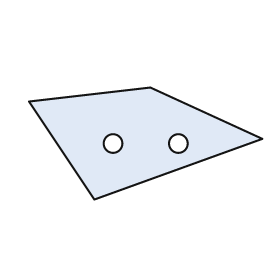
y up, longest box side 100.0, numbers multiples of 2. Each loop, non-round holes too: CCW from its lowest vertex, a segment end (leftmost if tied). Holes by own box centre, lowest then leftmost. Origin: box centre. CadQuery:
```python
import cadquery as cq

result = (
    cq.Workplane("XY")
    .moveTo(-22.0, -24.0)
    .lineTo(50.0, 2.0)
    .lineTo(2.0, 24.0)
    .lineTo(-50.0, 18.0)
    .close()
    .moveTo(-14.0, 0.0)
    .circle(4.0)
    .moveTo(14.0, 0.0)
    .circle(4.0)
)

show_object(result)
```